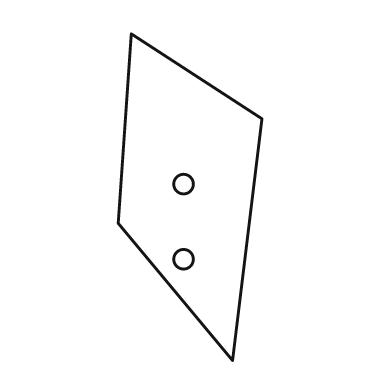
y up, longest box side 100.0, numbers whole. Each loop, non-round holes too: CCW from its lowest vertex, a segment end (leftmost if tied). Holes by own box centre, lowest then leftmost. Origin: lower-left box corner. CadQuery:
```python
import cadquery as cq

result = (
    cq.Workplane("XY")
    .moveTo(35.0, 0.0)
    .lineTo(44.0, 74.0)
    .lineTo(4.0, 100.0)
    .lineTo(0.0, 42.0)
    .close()
    .moveTo(20.0, 31.0)
    .circle(3.0)
    .moveTo(20.0, 54.0)
    .circle(3.0)
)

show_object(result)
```